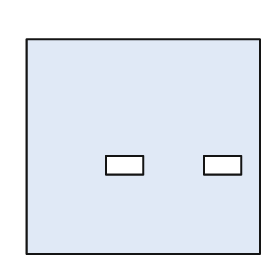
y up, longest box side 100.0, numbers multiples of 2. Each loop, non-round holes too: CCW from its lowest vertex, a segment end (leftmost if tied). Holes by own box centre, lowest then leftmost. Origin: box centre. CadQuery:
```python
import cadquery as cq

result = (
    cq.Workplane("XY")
    .moveTo(-50.0, -46.0)
    .lineTo(50.0, -46.0)
    .lineTo(50.0, 46.0)
    .lineTo(-50.0, 46.0)
    .close()
    .moveTo(-16.0, -12.0)
    .lineTo(0.0, -12.0)
    .lineTo(0.0, -4.0)
    .lineTo(-16.0, -4.0)
    .close()
    .moveTo(26.0, -12.0)
    .lineTo(42.0, -12.0)
    .lineTo(42.0, -4.0)
    .lineTo(26.0, -4.0)
    .close()
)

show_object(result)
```